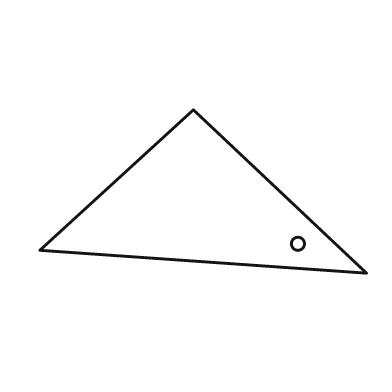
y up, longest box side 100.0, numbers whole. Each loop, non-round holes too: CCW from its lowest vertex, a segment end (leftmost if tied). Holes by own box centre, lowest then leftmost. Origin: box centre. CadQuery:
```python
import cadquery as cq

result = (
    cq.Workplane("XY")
    .moveTo(50.0, -25.0)
    .lineTo(-3.0, 25.0)
    .lineTo(-50.0, -18.0)
    .close()
    .moveTo(29.0, -16.0)
    .circle(2.0)
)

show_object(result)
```